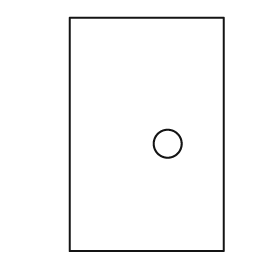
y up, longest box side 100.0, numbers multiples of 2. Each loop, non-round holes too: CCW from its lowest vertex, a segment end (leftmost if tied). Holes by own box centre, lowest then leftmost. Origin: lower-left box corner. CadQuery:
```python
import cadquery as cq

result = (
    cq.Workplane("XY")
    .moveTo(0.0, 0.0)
    .lineTo(66.0, 0.0)
    .lineTo(66.0, 100.0)
    .lineTo(0.0, 100.0)
    .close()
    .moveTo(42.0, 46.0)
    .circle(6.0)
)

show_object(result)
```